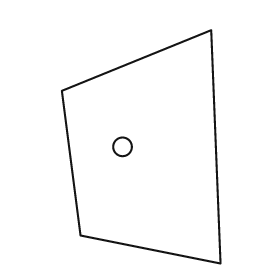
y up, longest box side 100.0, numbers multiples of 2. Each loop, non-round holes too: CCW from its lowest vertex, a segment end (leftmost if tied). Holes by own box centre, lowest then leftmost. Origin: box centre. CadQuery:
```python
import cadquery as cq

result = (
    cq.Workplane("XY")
    .moveTo(34.0, -50.0)
    .lineTo(30.0, 50.0)
    .lineTo(-34.0, 24.0)
    .lineTo(-26.0, -38.0)
    .close()
    .moveTo(-8.0, 0.0)
    .circle(4.0)
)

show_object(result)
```